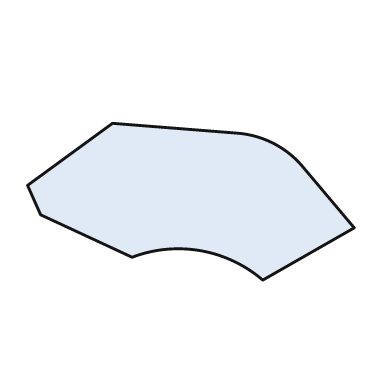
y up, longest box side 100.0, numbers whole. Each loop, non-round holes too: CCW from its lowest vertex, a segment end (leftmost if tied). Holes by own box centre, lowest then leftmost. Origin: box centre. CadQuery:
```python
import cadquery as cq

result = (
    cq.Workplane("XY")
    .moveTo(22.0, -24.0)
    .lineTo(50.0, -8.0)
    .lineTo(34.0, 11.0)
    .threePointArc((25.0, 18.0), (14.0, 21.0))
    .lineTo(-24.0, 24.0)
    .lineTo(-50.0, 5.0)
    .lineTo(-46.0, -4.0)
    .lineTo(-18.0, -17.0)
    .threePointArc((3.0, -15.0), (22.0, -24.0))
    .close()
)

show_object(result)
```